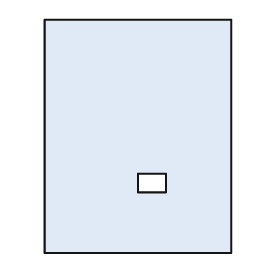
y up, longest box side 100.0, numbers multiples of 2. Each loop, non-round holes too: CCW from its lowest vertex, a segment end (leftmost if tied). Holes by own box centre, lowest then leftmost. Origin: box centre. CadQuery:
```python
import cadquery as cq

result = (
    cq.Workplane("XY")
    .moveTo(-40.0, -50.0)
    .lineTo(40.0, -50.0)
    .lineTo(40.0, 50.0)
    .lineTo(-40.0, 50.0)
    .close()
    .moveTo(0.0, -24.0)
    .lineTo(12.0, -24.0)
    .lineTo(12.0, -16.0)
    .lineTo(0.0, -16.0)
    .close()
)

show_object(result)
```